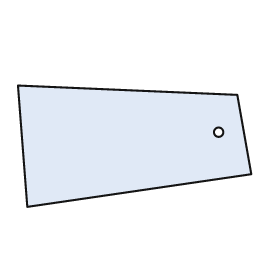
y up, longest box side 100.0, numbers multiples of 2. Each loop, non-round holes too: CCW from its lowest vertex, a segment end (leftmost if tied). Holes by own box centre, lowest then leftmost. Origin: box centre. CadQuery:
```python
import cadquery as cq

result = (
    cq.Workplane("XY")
    .moveTo(-46.0, -26.0)
    .lineTo(50.0, -12.0)
    .lineTo(44.0, 22.0)
    .lineTo(-50.0, 26.0)
    .close()
    .moveTo(36.0, 6.0)
    .circle(2.0)
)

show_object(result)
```